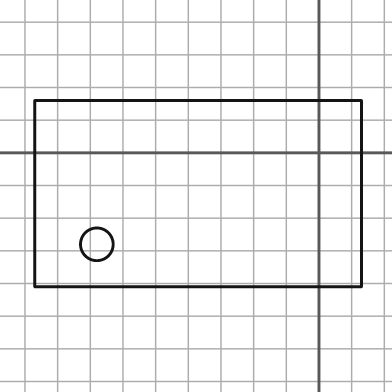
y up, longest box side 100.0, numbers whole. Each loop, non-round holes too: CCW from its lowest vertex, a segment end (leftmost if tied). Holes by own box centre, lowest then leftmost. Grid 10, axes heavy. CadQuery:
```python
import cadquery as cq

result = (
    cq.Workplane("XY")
    .moveTo(-87.0, -41.0)
    .lineTo(13.0, -41.0)
    .lineTo(13.0, 16.0)
    .lineTo(-87.0, 16.0)
    .close()
    .moveTo(-68.0, -28.0)
    .circle(5.0)
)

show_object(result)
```